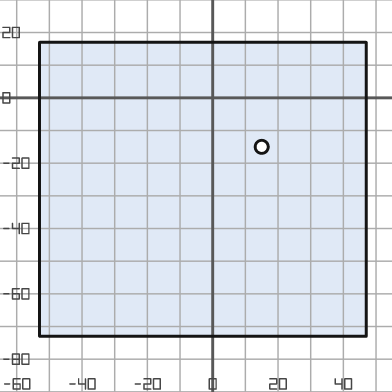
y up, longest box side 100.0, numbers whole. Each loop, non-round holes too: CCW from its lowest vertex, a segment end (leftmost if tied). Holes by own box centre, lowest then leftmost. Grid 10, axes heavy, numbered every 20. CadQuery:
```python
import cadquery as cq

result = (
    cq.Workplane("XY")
    .moveTo(-53.0, -73.0)
    .lineTo(47.0, -73.0)
    .lineTo(47.0, 17.0)
    .lineTo(-53.0, 17.0)
    .close()
    .moveTo(15.0, -15.0)
    .circle(2.0)
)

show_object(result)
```